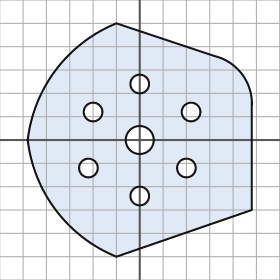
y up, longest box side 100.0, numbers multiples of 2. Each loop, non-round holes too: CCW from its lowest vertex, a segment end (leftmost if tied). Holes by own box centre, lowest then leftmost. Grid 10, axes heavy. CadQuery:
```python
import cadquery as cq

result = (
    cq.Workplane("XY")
    .moveTo(-10.0, -50.0)
    .lineTo(48.0, -30.0)
    .lineTo(48.0, 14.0)
    .threePointArc((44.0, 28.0), (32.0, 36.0))
    .lineTo(-10.0, 50.0)
    .threePointArc((-36.0, 30.0), (-48.0, 0.0))
    .threePointArc((-36.0, -30.0), (-10.0, -50.0))
    .close()
    .moveTo(0.0, -24.0)
    .circle(4.0)
    .moveTo(-22.0, -12.0)
    .circle(4.0)
    .moveTo(20.0, -12.0)
    .circle(4.0)
    .moveTo(0.0, 0.0)
    .circle(6.0)
    .moveTo(-20.0, 12.0)
    .circle(4.0)
    .moveTo(22.0, 12.0)
    .circle(4.0)
    .moveTo(0.0, 24.0)
    .circle(4.0)
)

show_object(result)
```